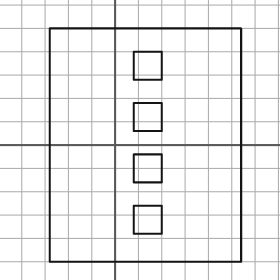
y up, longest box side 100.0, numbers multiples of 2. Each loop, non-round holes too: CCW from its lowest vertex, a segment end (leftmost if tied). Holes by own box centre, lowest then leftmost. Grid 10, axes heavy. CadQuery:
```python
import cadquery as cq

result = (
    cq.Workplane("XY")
    .moveTo(-28.0, -50.0)
    .lineTo(54.0, -50.0)
    .lineTo(54.0, 50.0)
    .lineTo(-28.0, 50.0)
    .close()
    .moveTo(8.0, -38.0)
    .lineTo(20.0, -38.0)
    .lineTo(20.0, -26.0)
    .lineTo(8.0, -26.0)
    .close()
    .moveTo(8.0, -16.0)
    .lineTo(20.0, -16.0)
    .lineTo(20.0, -4.0)
    .lineTo(8.0, -4.0)
    .close()
    .moveTo(8.0, 6.0)
    .lineTo(20.0, 6.0)
    .lineTo(20.0, 18.0)
    .lineTo(8.0, 18.0)
    .close()
    .moveTo(8.0, 28.0)
    .lineTo(20.0, 28.0)
    .lineTo(20.0, 40.0)
    .lineTo(8.0, 40.0)
    .close()
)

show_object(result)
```